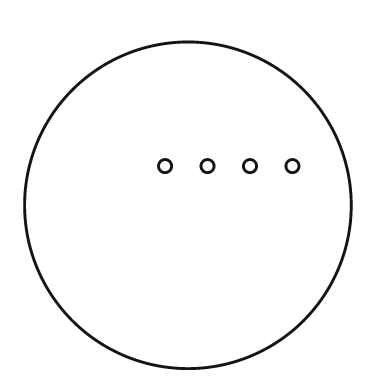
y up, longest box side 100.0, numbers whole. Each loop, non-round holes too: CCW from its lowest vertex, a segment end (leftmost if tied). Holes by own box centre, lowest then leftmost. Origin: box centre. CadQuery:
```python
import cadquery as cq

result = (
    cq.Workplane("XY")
    .moveTo(0.0, 0.0)
    .circle(50.0)
    .moveTo(-7.0, 12.0)
    .circle(2.0)
    .moveTo(6.0, 12.0)
    .circle(2.0)
    .moveTo(19.0, 12.0)
    .circle(2.0)
    .moveTo(32.0, 12.0)
    .circle(2.0)
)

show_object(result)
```